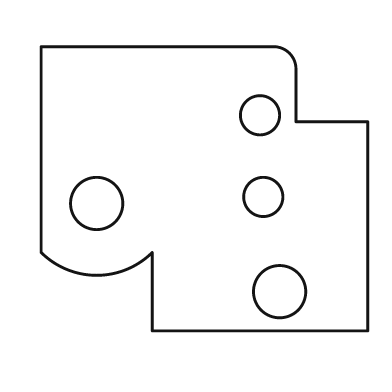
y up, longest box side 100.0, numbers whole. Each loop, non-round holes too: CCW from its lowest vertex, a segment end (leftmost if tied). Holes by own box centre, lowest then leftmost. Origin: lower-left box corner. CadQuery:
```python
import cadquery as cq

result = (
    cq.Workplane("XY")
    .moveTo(34.0, 0.0)
    .lineTo(100.0, 0.0)
    .lineTo(100.0, 64.0)
    .lineTo(78.0, 64.0)
    .lineTo(78.0, 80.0)
    .threePointArc((76.0, 85.0), (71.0, 87.0))
    .lineTo(0.0, 87.0)
    .lineTo(0.0, 24.0)
    .threePointArc((17.0, 17.0), (34.0, 24.0))
    .close()
    .moveTo(73.0, 12.0)
    .circle(8.0)
    .moveTo(17.0, 39.0)
    .circle(8.0)
    .moveTo(68.0, 41.0)
    .circle(6.0)
    .moveTo(67.0, 66.0)
    .circle(6.0)
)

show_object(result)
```